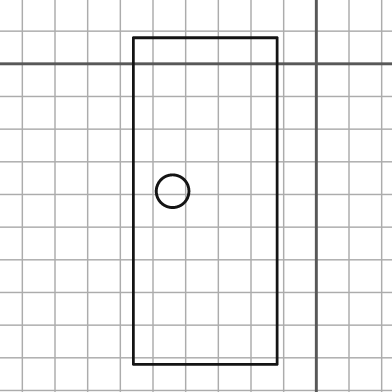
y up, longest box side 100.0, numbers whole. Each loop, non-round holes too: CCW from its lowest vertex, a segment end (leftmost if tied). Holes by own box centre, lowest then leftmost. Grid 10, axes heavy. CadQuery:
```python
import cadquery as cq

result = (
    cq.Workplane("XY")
    .moveTo(-56.0, -92.0)
    .lineTo(-12.0, -92.0)
    .lineTo(-12.0, 8.0)
    .lineTo(-56.0, 8.0)
    .close()
    .moveTo(-44.0, -39.0)
    .circle(5.0)
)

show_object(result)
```